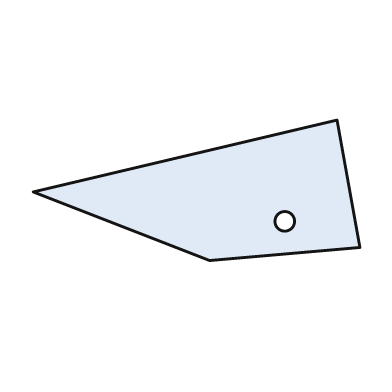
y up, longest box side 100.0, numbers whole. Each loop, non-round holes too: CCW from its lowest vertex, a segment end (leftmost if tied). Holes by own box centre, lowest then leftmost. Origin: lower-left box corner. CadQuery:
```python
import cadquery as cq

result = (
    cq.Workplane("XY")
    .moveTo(54.0, 0.0)
    .lineTo(100.0, 4.0)
    .lineTo(93.0, 43.0)
    .lineTo(0.0, 21.0)
    .close()
    .moveTo(77.0, 12.0)
    .circle(3.0)
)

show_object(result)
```